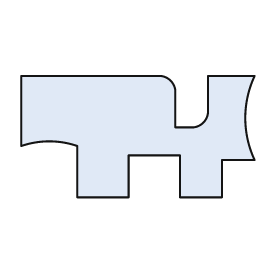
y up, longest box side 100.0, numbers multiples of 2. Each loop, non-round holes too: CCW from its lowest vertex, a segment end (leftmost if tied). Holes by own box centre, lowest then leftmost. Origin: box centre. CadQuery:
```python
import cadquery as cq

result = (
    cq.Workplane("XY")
    .moveTo(-26.0, -26.0)
    .lineTo(-4.0, -26.0)
    .lineTo(-4.0, -8.0)
    .lineTo(18.0, -8.0)
    .lineTo(18.0, -26.0)
    .lineTo(36.0, -26.0)
    .lineTo(36.0, -10.0)
    .lineTo(50.0, -10.0)
    .threePointArc((46.0, 8.0), (50.0, 26.0))
    .lineTo(30.0, 26.0)
    .lineTo(30.0, 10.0)
    .threePointArc((28.0, 6.0), (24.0, 4.0))
    .lineTo(16.0, 4.0)
    .lineTo(16.0, 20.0)
    .threePointArc((14.0, 24.0), (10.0, 26.0))
    .lineTo(-50.0, 26.0)
    .lineTo(-50.0, -4.0)
    .threePointArc((-38.0, -2.0), (-26.0, -4.0))
    .close()
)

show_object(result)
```